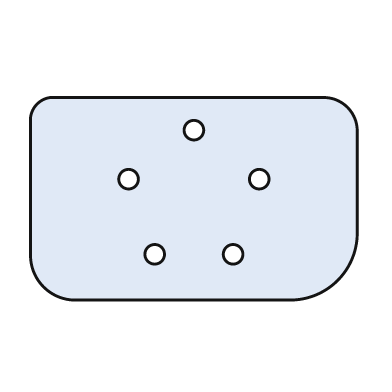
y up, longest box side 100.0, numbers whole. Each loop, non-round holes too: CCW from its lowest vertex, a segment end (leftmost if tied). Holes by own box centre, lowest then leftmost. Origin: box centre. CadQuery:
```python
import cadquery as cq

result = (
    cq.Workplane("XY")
    .moveTo(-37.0, -31.0)
    .lineTo(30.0, -31.0)
    .threePointArc((44.0, -25.0), (50.0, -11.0))
    .lineTo(50.0, 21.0)
    .threePointArc((47.0, 28.0), (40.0, 31.0))
    .lineTo(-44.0, 31.0)
    .threePointArc((-48.0, 29.0), (-50.0, 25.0))
    .lineTo(-50.0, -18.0)
    .threePointArc((-46.0, -27.0), (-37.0, -31.0))
    .close()
    .moveTo(-12.0, -17.0)
    .circle(3.0)
    .moveTo(12.0, -17.0)
    .circle(3.0)
    .moveTo(-20.0, 6.0)
    .circle(3.0)
    .moveTo(20.0, 6.0)
    .circle(3.0)
    .moveTo(0.0, 21.0)
    .circle(3.0)
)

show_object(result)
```